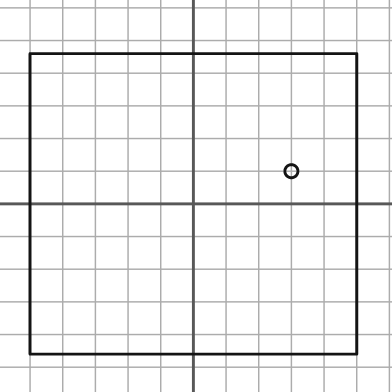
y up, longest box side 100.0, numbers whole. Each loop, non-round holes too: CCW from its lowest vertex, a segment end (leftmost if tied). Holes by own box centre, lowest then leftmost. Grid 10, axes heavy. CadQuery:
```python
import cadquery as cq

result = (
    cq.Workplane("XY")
    .moveTo(-50.0, -46.0)
    .lineTo(50.0, -46.0)
    .lineTo(50.0, 46.0)
    .lineTo(-50.0, 46.0)
    .close()
    .moveTo(30.0, 10.0)
    .circle(2.0)
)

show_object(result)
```